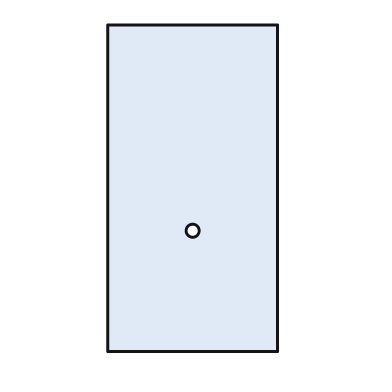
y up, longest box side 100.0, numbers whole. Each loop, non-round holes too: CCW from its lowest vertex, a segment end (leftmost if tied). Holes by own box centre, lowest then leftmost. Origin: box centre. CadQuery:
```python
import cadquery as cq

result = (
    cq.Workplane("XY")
    .moveTo(-26.0, -50.0)
    .lineTo(26.0, -50.0)
    .lineTo(26.0, 50.0)
    .lineTo(-26.0, 50.0)
    .close()
    .moveTo(0.0, -13.0)
    .circle(2.0)
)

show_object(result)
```